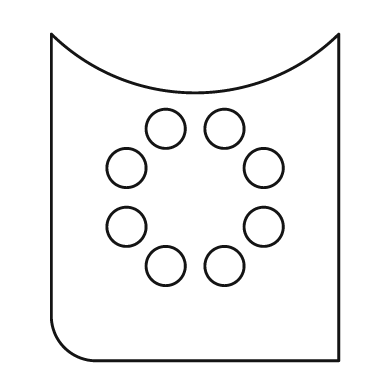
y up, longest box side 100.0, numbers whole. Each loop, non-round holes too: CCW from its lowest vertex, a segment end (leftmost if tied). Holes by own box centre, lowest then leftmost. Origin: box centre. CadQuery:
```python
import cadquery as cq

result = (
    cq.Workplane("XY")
    .moveTo(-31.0, -50.0)
    .lineTo(44.0, -50.0)
    .lineTo(44.0, 50.0)
    .threePointArc((0.0, 32.0), (-44.0, 50.0))
    .lineTo(-44.0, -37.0)
    .threePointArc((-40.0, -46.0), (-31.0, -50.0))
    .close()
    .moveTo(-9.0, -21.0)
    .circle(6.0)
    .moveTo(9.0, -21.0)
    .circle(6.0)
    .moveTo(-21.0, -9.0)
    .circle(6.0)
    .moveTo(21.0, -9.0)
    .circle(6.0)
    .moveTo(-21.0, 9.0)
    .circle(6.0)
    .moveTo(21.0, 9.0)
    .circle(6.0)
    .moveTo(-9.0, 21.0)
    .circle(6.0)
    .moveTo(9.0, 21.0)
    .circle(6.0)
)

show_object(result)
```